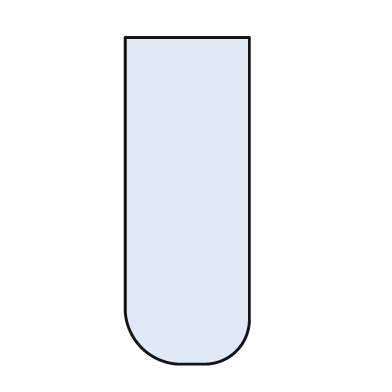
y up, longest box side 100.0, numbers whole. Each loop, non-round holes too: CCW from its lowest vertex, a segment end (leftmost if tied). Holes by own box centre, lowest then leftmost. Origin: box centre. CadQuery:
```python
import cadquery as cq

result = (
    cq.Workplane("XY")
    .moveTo(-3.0, -50.0)
    .lineTo(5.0, -50.0)
    .threePointArc((15.0, -46.0), (19.0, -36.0))
    .lineTo(19.0, 50.0)
    .lineTo(-19.0, 50.0)
    .lineTo(-19.0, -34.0)
    .threePointArc((-14.0, -45.0), (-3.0, -50.0))
    .close()
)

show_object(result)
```